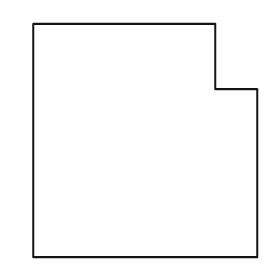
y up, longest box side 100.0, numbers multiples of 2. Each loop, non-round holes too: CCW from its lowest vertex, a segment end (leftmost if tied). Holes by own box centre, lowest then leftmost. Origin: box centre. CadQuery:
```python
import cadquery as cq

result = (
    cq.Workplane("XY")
    .moveTo(-48.0, -50.0)
    .lineTo(48.0, -50.0)
    .lineTo(48.0, 22.0)
    .lineTo(30.0, 22.0)
    .lineTo(30.0, 50.0)
    .lineTo(-48.0, 50.0)
    .close()
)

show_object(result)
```